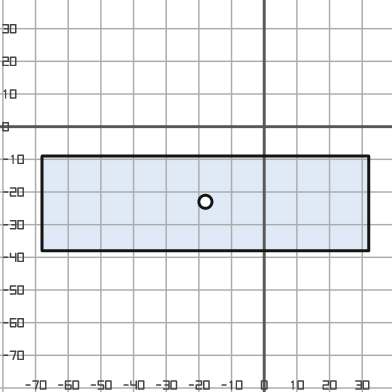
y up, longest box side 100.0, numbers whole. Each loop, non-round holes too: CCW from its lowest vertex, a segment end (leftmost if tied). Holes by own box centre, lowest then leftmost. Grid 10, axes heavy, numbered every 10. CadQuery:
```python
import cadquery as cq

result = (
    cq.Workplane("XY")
    .moveTo(-68.0, -38.0)
    .lineTo(32.0, -38.0)
    .lineTo(32.0, -9.0)
    .lineTo(-68.0, -9.0)
    .close()
    .moveTo(-18.0, -23.0)
    .circle(2.0)
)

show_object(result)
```